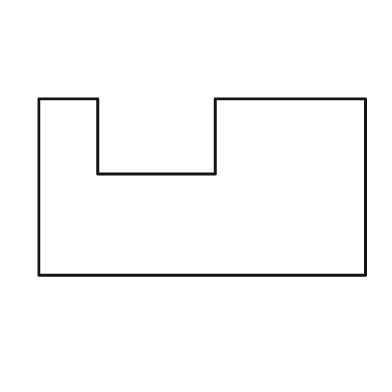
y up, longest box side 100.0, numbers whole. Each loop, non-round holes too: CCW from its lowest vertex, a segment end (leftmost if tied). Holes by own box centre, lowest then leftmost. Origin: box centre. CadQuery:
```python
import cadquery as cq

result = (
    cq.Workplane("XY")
    .moveTo(-50.0, -27.0)
    .lineTo(50.0, -27.0)
    .lineTo(50.0, 27.0)
    .lineTo(4.0, 27.0)
    .lineTo(4.0, 4.0)
    .lineTo(-32.0, 4.0)
    .lineTo(-32.0, 27.0)
    .lineTo(-50.0, 27.0)
    .close()
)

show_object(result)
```